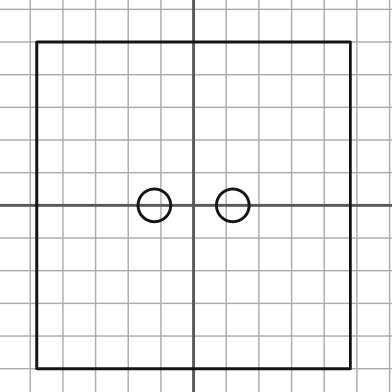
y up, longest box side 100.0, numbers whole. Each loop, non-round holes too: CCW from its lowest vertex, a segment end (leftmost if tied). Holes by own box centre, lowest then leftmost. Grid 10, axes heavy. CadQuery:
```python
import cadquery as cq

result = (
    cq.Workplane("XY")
    .moveTo(-48.0, -50.0)
    .lineTo(48.0, -50.0)
    .lineTo(48.0, 50.0)
    .lineTo(-48.0, 50.0)
    .close()
    .moveTo(-12.0, 0.0)
    .circle(5.0)
    .moveTo(12.0, 0.0)
    .circle(5.0)
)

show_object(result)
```